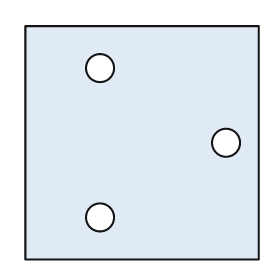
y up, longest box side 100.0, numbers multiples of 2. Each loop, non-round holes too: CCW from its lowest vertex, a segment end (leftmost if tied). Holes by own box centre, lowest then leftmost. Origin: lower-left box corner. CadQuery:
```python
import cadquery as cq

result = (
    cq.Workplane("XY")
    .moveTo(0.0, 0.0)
    .lineTo(100.0, 0.0)
    .lineTo(100.0, 100.0)
    .lineTo(0.0, 100.0)
    .close()
    .moveTo(32.0, 18.0)
    .circle(6.0)
    .moveTo(86.0, 50.0)
    .circle(6.0)
    .moveTo(32.0, 82.0)
    .circle(6.0)
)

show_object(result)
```